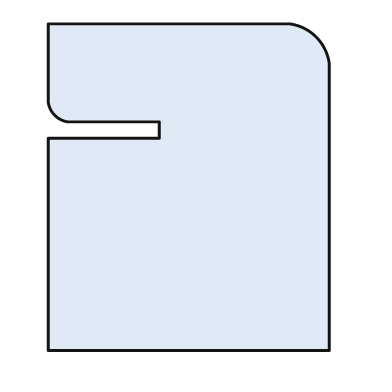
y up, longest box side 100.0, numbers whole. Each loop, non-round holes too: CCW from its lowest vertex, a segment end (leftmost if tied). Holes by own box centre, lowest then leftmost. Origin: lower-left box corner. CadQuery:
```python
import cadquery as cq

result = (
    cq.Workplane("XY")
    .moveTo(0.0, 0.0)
    .lineTo(86.0, 0.0)
    .lineTo(86.0, 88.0)
    .threePointArc((82.0, 96.0), (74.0, 100.0))
    .lineTo(0.0, 100.0)
    .lineTo(0.0, 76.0)
    .threePointArc((2.0, 72.0), (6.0, 70.0))
    .lineTo(34.0, 70.0)
    .lineTo(34.0, 65.0)
    .lineTo(0.0, 65.0)
    .close()
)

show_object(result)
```